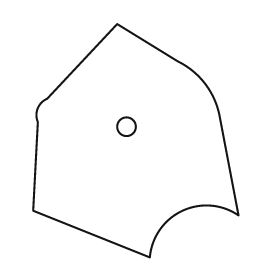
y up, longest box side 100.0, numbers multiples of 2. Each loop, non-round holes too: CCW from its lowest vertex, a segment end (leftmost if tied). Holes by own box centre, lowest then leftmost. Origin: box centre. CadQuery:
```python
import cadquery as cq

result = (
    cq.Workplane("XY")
    .moveTo(6.0, -50.0)
    .threePointArc((20.0, -30.0), (44.0, -32.0))
    .lineTo(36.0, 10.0)
    .threePointArc((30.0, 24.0), (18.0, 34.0))
    .lineTo(-8.0, 50.0)
    .lineTo(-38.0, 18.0)
    .threePointArc((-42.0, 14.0), (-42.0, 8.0))
    .lineTo(-44.0, -30.0)
    .close()
    .moveTo(-4.0, 6.0)
    .circle(4.0)
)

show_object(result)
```